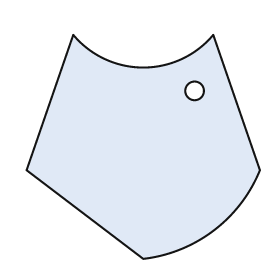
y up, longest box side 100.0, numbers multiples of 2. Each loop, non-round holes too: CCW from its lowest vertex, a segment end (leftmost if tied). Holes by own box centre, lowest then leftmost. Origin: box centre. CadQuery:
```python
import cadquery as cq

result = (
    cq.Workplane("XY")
    .moveTo(0.0, -48.0)
    .threePointArc((30.0, -36.0), (50.0, -10.0))
    .lineTo(30.0, 48.0)
    .threePointArc((0.0, 34.0), (-30.0, 48.0))
    .lineTo(-50.0, -10.0)
    .close()
    .moveTo(22.0, 24.0)
    .circle(4.0)
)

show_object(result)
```